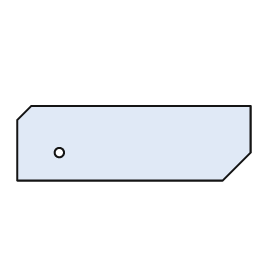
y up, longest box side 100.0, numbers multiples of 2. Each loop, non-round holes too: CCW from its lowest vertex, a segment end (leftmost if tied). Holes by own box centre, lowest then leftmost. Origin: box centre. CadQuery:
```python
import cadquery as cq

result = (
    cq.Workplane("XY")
    .moveTo(-50.0, -16.0)
    .lineTo(38.0, -16.0)
    .lineTo(50.0, -4.0)
    .lineTo(50.0, 16.0)
    .lineTo(-44.0, 16.0)
    .lineTo(-50.0, 10.0)
    .close()
    .moveTo(-32.0, -4.0)
    .circle(2.0)
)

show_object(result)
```